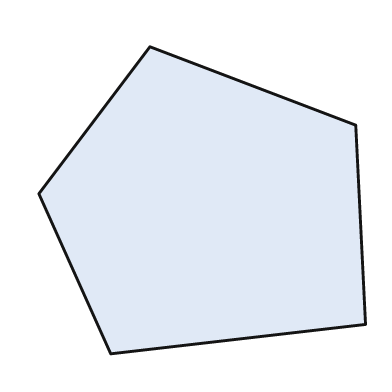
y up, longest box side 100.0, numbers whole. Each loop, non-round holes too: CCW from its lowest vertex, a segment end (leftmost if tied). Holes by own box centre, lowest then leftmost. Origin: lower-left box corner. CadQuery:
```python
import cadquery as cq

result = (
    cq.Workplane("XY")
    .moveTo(22.0, 0.0)
    .lineTo(100.0, 9.0)
    .lineTo(97.0, 70.0)
    .lineTo(34.0, 94.0)
    .lineTo(0.0, 49.0)
    .close()
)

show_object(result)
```